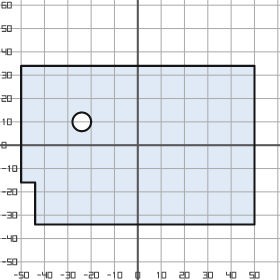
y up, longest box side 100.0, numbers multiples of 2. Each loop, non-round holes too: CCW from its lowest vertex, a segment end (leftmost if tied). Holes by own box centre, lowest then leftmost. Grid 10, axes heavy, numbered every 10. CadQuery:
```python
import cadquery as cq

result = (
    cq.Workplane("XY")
    .moveTo(-44.0, -34.0)
    .lineTo(50.0, -34.0)
    .lineTo(50.0, 34.0)
    .lineTo(-50.0, 34.0)
    .lineTo(-50.0, -16.0)
    .lineTo(-44.0, -16.0)
    .close()
    .moveTo(-24.0, 10.0)
    .circle(4.0)
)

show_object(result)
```